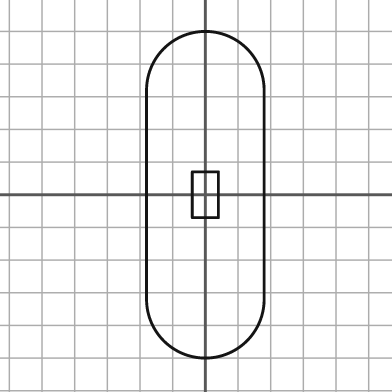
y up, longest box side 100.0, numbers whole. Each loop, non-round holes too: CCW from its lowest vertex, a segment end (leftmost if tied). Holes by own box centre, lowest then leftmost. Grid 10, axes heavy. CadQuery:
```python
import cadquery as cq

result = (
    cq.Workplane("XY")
    .moveTo(-18.0, -32.0)
    .threePointArc((0.0, -50.0), (18.0, -32.0))
    .lineTo(18.0, 32.0)
    .threePointArc((0.0, 50.0), (-18.0, 32.0))
    .close()
    .moveTo(-4.0, -7.0)
    .lineTo(4.0, -7.0)
    .lineTo(4.0, 7.0)
    .lineTo(-4.0, 7.0)
    .close()
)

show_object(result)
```